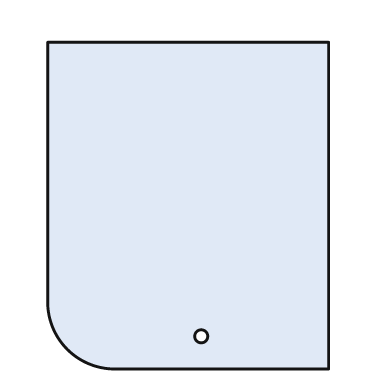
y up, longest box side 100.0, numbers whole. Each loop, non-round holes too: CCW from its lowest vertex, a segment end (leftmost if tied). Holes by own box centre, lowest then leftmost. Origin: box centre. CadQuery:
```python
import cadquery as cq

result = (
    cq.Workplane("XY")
    .moveTo(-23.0, -50.0)
    .lineTo(43.0, -50.0)
    .lineTo(43.0, 50.0)
    .lineTo(-43.0, 50.0)
    .lineTo(-43.0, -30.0)
    .threePointArc((-37.0, -44.0), (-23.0, -50.0))
    .close()
    .moveTo(4.0, -40.0)
    .circle(2.0)
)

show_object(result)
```